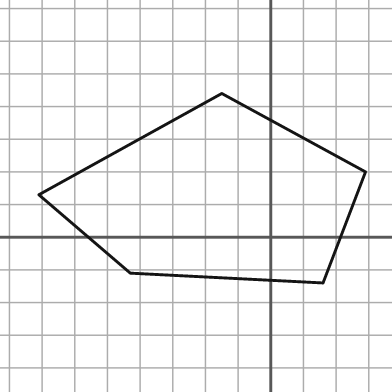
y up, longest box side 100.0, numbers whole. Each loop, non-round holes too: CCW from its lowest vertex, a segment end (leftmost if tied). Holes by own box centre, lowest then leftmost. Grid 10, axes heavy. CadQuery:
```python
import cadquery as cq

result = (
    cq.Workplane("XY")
    .moveTo(16.0, -14.0)
    .lineTo(29.0, 20.0)
    .lineTo(-15.0, 44.0)
    .lineTo(-71.0, 13.0)
    .lineTo(-43.0, -11.0)
    .close()
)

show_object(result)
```